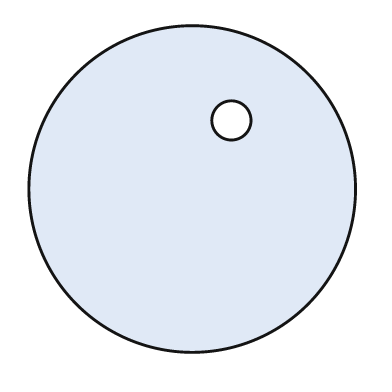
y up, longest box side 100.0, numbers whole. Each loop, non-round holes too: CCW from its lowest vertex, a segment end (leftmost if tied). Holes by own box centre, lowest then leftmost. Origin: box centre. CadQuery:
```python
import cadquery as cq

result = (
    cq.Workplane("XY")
    .moveTo(0.0, 0.0)
    .circle(50.0)
    .moveTo(12.0, 21.0)
    .circle(6.0)
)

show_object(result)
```